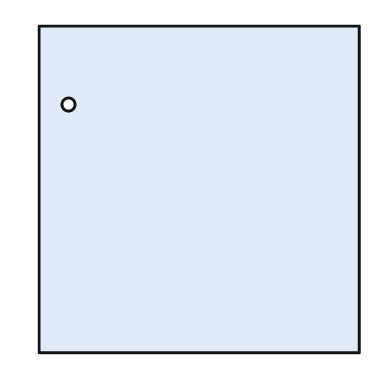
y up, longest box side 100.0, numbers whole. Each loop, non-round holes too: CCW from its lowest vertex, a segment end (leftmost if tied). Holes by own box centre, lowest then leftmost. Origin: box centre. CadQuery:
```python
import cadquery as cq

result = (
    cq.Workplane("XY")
    .moveTo(-49.0, -50.0)
    .lineTo(49.0, -50.0)
    .lineTo(49.0, 50.0)
    .lineTo(-49.0, 50.0)
    .close()
    .moveTo(-40.0, 26.0)
    .circle(2.0)
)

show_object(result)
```